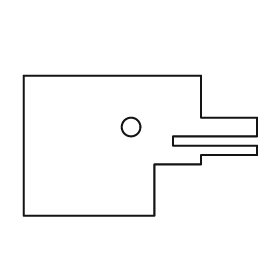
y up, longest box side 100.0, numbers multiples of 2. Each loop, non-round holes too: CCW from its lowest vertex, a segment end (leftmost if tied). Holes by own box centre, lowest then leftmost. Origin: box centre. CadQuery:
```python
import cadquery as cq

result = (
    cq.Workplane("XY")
    .moveTo(-50.0, -30.0)
    .lineTo(6.0, -30.0)
    .lineTo(6.0, -8.0)
    .lineTo(26.0, -8.0)
    .lineTo(26.0, -4.0)
    .lineTo(50.0, -4.0)
    .lineTo(50.0, 0.0)
    .lineTo(14.0, 0.0)
    .lineTo(14.0, 4.0)
    .lineTo(50.0, 4.0)
    .lineTo(50.0, 12.0)
    .lineTo(26.0, 12.0)
    .lineTo(26.0, 30.0)
    .lineTo(-50.0, 30.0)
    .close()
    .moveTo(-4.0, 8.0)
    .circle(4.0)
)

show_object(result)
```